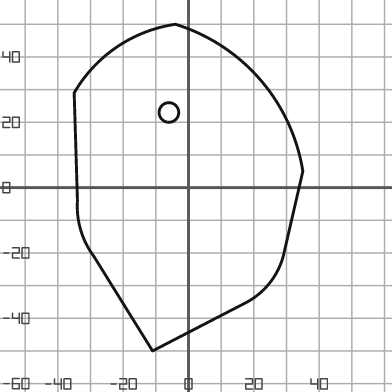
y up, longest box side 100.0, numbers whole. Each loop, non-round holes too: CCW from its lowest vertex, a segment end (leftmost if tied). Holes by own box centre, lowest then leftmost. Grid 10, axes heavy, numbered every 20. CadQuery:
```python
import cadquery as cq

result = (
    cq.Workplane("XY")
    .moveTo(-11.0, -50.0)
    .lineTo(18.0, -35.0)
    .threePointArc((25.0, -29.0), (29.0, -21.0))
    .lineTo(35.0, 5.0)
    .threePointArc((22.0, 33.0), (-4.0, 50.0))
    .threePointArc((-22.0, 43.0), (-35.0, 29.0))
    .lineTo(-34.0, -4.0)
    .threePointArc((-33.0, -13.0), (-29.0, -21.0))
    .close()
    .moveTo(-6.0, 23.0)
    .circle(3.0)
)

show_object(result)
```